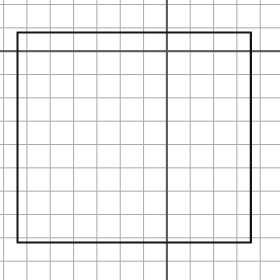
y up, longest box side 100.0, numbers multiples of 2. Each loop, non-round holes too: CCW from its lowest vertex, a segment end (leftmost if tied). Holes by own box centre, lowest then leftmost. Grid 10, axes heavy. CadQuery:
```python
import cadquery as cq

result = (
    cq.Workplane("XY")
    .moveTo(-64.0, -82.0)
    .lineTo(36.0, -82.0)
    .lineTo(36.0, 8.0)
    .lineTo(-64.0, 8.0)
    .close()
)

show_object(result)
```